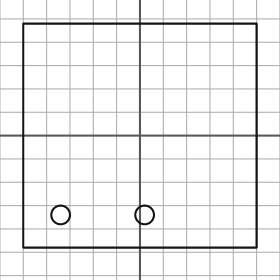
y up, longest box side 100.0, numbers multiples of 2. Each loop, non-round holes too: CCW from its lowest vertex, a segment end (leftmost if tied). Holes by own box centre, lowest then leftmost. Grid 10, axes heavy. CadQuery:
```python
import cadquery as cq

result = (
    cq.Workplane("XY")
    .moveTo(-50.0, -48.0)
    .lineTo(50.0, -48.0)
    .lineTo(50.0, 48.0)
    .lineTo(-50.0, 48.0)
    .close()
    .moveTo(-34.0, -34.0)
    .circle(4.0)
    .moveTo(2.0, -34.0)
    .circle(4.0)
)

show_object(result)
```